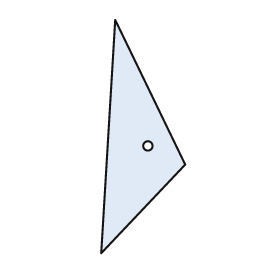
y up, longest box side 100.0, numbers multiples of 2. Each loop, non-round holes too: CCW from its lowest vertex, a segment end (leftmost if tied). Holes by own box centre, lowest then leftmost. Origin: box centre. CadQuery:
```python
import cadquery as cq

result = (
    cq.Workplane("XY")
    .moveTo(-18.0, -50.0)
    .lineTo(18.0, -12.0)
    .lineTo(-12.0, 50.0)
    .close()
    .moveTo(2.0, -4.0)
    .circle(2.0)
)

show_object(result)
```